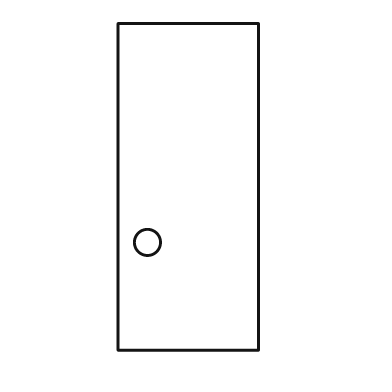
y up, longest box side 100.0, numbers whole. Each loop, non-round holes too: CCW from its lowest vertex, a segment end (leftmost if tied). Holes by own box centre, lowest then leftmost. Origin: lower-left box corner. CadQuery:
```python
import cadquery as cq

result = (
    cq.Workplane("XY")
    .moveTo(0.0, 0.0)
    .lineTo(43.0, 0.0)
    .lineTo(43.0, 100.0)
    .lineTo(0.0, 100.0)
    .close()
    .moveTo(9.0, 33.0)
    .circle(4.0)
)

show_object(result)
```